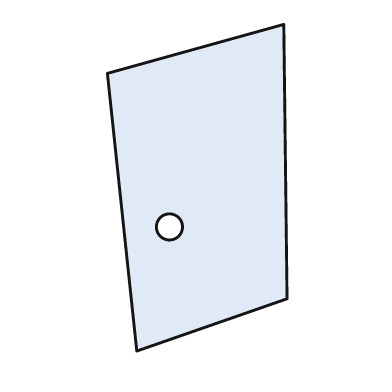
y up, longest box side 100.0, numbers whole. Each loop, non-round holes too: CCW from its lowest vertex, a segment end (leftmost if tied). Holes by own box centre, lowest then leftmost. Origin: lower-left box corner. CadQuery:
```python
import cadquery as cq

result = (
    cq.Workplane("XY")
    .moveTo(9.0, 0.0)
    .lineTo(55.0, 16.0)
    .lineTo(54.0, 100.0)
    .lineTo(0.0, 85.0)
    .close()
    .moveTo(19.0, 38.0)
    .circle(4.0)
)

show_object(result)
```